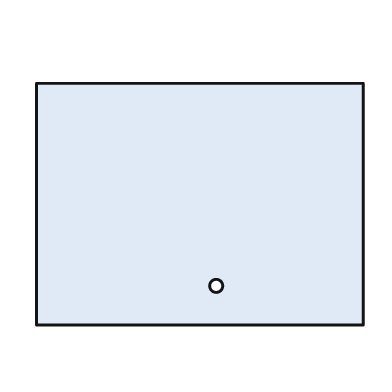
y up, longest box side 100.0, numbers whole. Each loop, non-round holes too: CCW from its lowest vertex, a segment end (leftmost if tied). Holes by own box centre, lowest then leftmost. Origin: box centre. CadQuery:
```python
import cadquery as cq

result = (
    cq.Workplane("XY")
    .moveTo(-50.0, -37.0)
    .lineTo(50.0, -37.0)
    .lineTo(50.0, 37.0)
    .lineTo(-50.0, 37.0)
    .close()
    .moveTo(5.0, -25.0)
    .circle(2.0)
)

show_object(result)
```